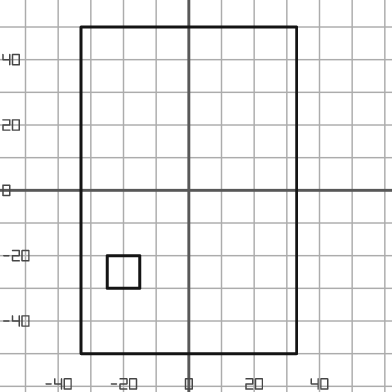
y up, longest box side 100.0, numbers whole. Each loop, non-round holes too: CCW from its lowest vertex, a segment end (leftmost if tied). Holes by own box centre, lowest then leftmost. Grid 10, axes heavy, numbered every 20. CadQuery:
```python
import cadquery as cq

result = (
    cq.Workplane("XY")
    .moveTo(-33.0, -50.0)
    .lineTo(33.0, -50.0)
    .lineTo(33.0, 50.0)
    .lineTo(-33.0, 50.0)
    .close()
    .moveTo(-25.0, -30.0)
    .lineTo(-15.0, -30.0)
    .lineTo(-15.0, -20.0)
    .lineTo(-25.0, -20.0)
    .close()
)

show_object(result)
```